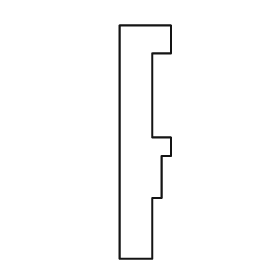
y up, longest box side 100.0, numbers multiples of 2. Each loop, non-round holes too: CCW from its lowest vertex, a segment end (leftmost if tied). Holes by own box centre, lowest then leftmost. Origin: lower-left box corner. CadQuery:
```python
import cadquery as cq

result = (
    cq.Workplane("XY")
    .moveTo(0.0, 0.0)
    .lineTo(14.0, 0.0)
    .lineTo(14.0, 26.0)
    .lineTo(18.0, 26.0)
    .lineTo(18.0, 44.0)
    .lineTo(22.0, 44.0)
    .lineTo(22.0, 52.0)
    .lineTo(14.0, 52.0)
    .lineTo(14.0, 88.0)
    .lineTo(22.0, 88.0)
    .lineTo(22.0, 100.0)
    .lineTo(0.0, 100.0)
    .close()
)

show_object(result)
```